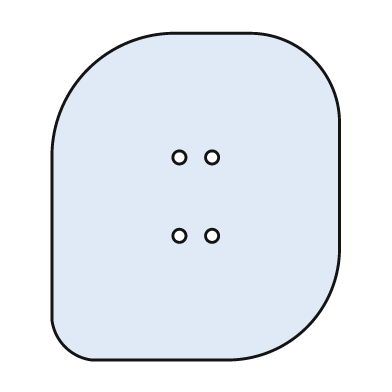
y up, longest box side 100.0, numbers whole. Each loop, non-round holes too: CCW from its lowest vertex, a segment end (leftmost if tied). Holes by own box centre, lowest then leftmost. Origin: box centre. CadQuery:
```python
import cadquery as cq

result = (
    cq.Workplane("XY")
    .moveTo(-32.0, -50.0)
    .lineTo(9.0, -50.0)
    .threePointArc((34.0, -40.0), (44.0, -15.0))
    .lineTo(44.0, 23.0)
    .threePointArc((36.0, 42.0), (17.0, 50.0))
    .lineTo(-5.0, 50.0)
    .threePointArc((-33.0, 39.0), (-44.0, 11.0))
    .lineTo(-44.0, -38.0)
    .threePointArc((-40.0, -46.0), (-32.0, -50.0))
    .close()
    .moveTo(-5.0, -12.0)
    .circle(2.0)
    .moveTo(5.0, -12.0)
    .circle(2.0)
    .moveTo(-5.0, 12.0)
    .circle(2.0)
    .moveTo(5.0, 12.0)
    .circle(2.0)
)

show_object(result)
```